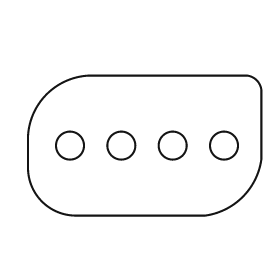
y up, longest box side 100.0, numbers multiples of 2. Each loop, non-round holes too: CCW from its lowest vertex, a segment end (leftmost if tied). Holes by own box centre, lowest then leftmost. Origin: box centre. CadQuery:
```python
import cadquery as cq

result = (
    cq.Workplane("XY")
    .moveTo(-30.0, -30.0)
    .lineTo(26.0, -30.0)
    .threePointArc((42.0, -22.0), (50.0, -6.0))
    .lineTo(50.0, 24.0)
    .threePointArc((48.0, 28.0), (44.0, 30.0))
    .lineTo(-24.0, 30.0)
    .threePointArc((-42.0, 22.0), (-50.0, 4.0))
    .lineTo(-50.0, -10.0)
    .threePointArc((-44.0, -24.0), (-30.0, -30.0))
    .close()
    .moveTo(-32.0, 0.0)
    .circle(6.0)
    .moveTo(-10.0, 0.0)
    .circle(6.0)
    .moveTo(12.0, 0.0)
    .circle(6.0)
    .moveTo(34.0, 0.0)
    .circle(6.0)
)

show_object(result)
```